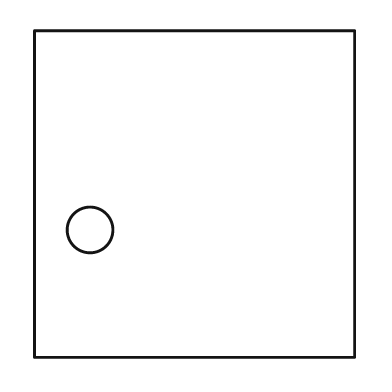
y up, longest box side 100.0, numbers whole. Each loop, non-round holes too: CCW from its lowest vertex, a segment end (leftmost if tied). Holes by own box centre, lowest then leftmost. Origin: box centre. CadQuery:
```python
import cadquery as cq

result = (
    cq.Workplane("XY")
    .moveTo(-49.0, -50.0)
    .lineTo(49.0, -50.0)
    .lineTo(49.0, 50.0)
    .lineTo(-49.0, 50.0)
    .close()
    .moveTo(-32.0, -11.0)
    .circle(7.0)
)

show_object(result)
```